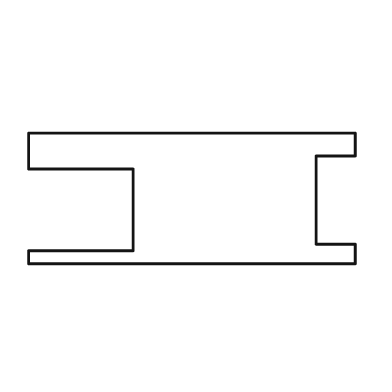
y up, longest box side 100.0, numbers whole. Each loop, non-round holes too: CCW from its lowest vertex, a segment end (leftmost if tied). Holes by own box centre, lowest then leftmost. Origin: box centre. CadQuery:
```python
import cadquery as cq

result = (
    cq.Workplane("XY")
    .moveTo(-50.0, -20.0)
    .lineTo(50.0, -20.0)
    .lineTo(50.0, -14.0)
    .lineTo(38.0, -14.0)
    .lineTo(38.0, 13.0)
    .lineTo(50.0, 13.0)
    .lineTo(50.0, 20.0)
    .lineTo(-50.0, 20.0)
    .lineTo(-50.0, 9.0)
    .lineTo(-18.0, 9.0)
    .lineTo(-18.0, -16.0)
    .lineTo(-50.0, -16.0)
    .close()
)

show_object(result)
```